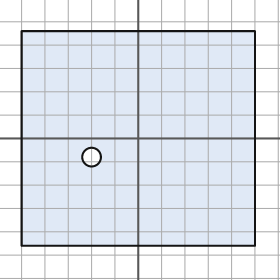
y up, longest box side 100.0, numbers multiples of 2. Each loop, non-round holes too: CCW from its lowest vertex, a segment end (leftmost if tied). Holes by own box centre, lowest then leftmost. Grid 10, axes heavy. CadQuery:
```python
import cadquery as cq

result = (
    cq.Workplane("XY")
    .moveTo(-50.0, -46.0)
    .lineTo(50.0, -46.0)
    .lineTo(50.0, 46.0)
    .lineTo(-50.0, 46.0)
    .close()
    .moveTo(-20.0, -8.0)
    .circle(4.0)
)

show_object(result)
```